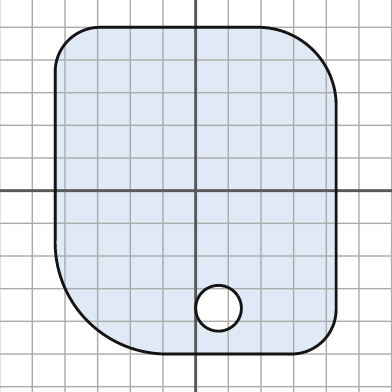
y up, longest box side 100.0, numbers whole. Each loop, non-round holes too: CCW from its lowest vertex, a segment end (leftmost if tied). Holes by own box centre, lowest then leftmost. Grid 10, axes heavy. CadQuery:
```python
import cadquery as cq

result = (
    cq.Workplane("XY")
    .moveTo(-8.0, -50.0)
    .lineTo(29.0, -50.0)
    .threePointArc((39.0, -46.0), (43.0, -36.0))
    .lineTo(43.0, 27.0)
    .threePointArc((36.0, 43.0), (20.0, 50.0))
    .lineTo(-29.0, 50.0)
    .threePointArc((-39.0, 46.0), (-43.0, 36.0))
    .lineTo(-43.0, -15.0)
    .threePointArc((-33.0, -40.0), (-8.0, -50.0))
    .close()
    .moveTo(7.0, -36.0)
    .circle(7.0)
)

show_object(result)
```